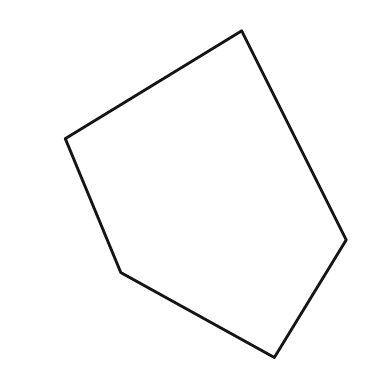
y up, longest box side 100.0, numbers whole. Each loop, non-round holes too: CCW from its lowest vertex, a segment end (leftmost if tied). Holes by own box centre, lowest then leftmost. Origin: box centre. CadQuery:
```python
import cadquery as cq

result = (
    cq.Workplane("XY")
    .moveTo(21.0, -50.0)
    .lineTo(43.0, -14.0)
    .lineTo(11.0, 50.0)
    .lineTo(-43.0, 17.0)
    .lineTo(-26.0, -24.0)
    .close()
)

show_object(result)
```